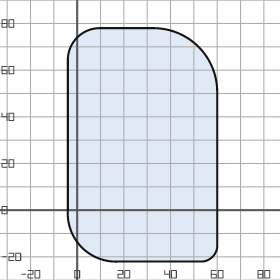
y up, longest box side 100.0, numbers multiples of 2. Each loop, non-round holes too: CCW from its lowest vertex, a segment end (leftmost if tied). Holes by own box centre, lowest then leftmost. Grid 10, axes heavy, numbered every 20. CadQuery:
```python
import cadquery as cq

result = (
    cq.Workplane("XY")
    .moveTo(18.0, -22.0)
    .lineTo(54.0, -22.0)
    .threePointArc((58.0, -20.0), (60.0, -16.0))
    .lineTo(60.0, 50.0)
    .threePointArc((52.0, 70.0), (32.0, 78.0))
    .lineTo(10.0, 78.0)
    .threePointArc((0.0, 74.0), (-4.0, 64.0))
    .lineTo(-4.0, 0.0)
    .threePointArc((2.0, -16.0), (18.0, -22.0))
    .close()
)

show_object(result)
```